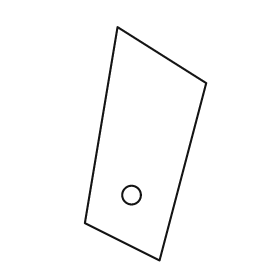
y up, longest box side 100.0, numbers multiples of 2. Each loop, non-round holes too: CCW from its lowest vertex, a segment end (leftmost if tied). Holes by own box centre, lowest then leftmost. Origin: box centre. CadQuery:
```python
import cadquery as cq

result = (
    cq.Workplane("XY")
    .moveTo(6.0, -50.0)
    .lineTo(26.0, 26.0)
    .lineTo(-12.0, 50.0)
    .lineTo(-26.0, -34.0)
    .close()
    .moveTo(-6.0, -22.0)
    .circle(4.0)
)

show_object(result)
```